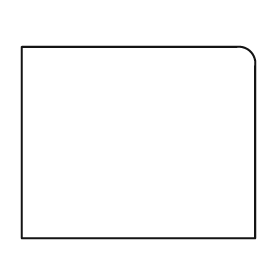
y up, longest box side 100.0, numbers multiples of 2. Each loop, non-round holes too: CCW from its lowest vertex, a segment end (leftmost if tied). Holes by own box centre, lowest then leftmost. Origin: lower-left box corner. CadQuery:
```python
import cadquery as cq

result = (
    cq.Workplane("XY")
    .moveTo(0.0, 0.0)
    .lineTo(100.0, 0.0)
    .lineTo(100.0, 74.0)
    .threePointArc((98.0, 80.0), (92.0, 82.0))
    .lineTo(0.0, 82.0)
    .close()
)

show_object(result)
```